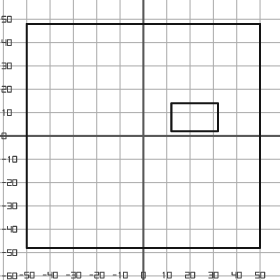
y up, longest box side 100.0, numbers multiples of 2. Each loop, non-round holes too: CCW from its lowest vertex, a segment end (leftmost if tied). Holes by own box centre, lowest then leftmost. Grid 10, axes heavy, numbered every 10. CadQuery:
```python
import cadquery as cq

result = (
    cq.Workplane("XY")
    .moveTo(-50.0, -48.0)
    .lineTo(50.0, -48.0)
    .lineTo(50.0, 48.0)
    .lineTo(-50.0, 48.0)
    .close()
    .moveTo(12.0, 2.0)
    .lineTo(32.0, 2.0)
    .lineTo(32.0, 14.0)
    .lineTo(12.0, 14.0)
    .close()
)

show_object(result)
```